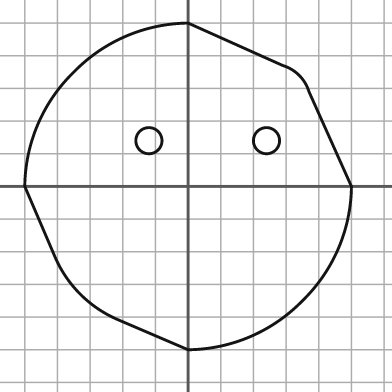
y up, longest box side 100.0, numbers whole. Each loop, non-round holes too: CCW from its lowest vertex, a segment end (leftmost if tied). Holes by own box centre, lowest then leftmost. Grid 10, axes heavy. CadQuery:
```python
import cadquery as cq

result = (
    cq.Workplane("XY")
    .moveTo(0.0, -50.0)
    .threePointArc((19.0, -46.0), (35.0, -35.0))
    .threePointArc((46.0, -19.0), (50.0, 0.0))
    .lineTo(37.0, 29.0)
    .threePointArc((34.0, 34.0), (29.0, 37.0))
    .lineTo(0.0, 50.0)
    .threePointArc((-19.0, 46.0), (-35.0, 35.0))
    .threePointArc((-46.0, 19.0), (-50.0, 0.0))
    .lineTo(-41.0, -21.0)
    .threePointArc((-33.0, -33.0), (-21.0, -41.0))
    .close()
    .moveTo(-12.0, 14.0)
    .circle(4.0)
    .moveTo(24.0, 14.0)
    .circle(4.0)
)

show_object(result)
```